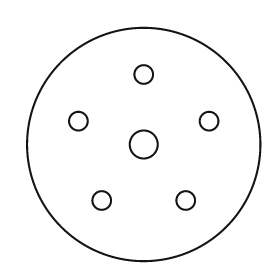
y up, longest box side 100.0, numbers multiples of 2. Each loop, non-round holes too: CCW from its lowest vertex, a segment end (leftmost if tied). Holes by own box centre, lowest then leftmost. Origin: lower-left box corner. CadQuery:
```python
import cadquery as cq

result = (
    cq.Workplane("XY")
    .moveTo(50.0, 50.0)
    .circle(50.0)
    .moveTo(32.0, 26.0)
    .circle(4.0)
    .moveTo(68.0, 26.0)
    .circle(4.0)
    .moveTo(50.0, 50.0)
    .circle(6.0)
    .moveTo(22.0, 60.0)
    .circle(4.0)
    .moveTo(78.0, 60.0)
    .circle(4.0)
    .moveTo(50.0, 80.0)
    .circle(4.0)
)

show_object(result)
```